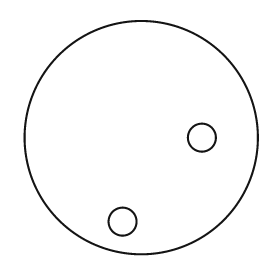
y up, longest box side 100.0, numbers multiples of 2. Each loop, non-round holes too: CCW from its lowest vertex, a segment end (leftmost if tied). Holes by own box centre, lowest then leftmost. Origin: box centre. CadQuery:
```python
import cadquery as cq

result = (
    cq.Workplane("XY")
    .moveTo(0.0, 0.0)
    .circle(50.0)
    .moveTo(-8.0, -36.0)
    .circle(6.0)
    .moveTo(26.0, 0.0)
    .circle(6.0)
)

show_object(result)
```